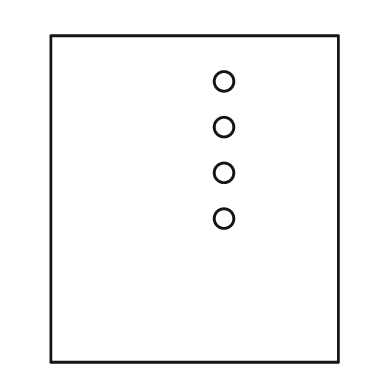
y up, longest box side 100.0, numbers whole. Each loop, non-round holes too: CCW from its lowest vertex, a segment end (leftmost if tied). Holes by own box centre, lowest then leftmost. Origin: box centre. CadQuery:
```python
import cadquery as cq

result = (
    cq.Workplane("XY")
    .moveTo(-44.0, -50.0)
    .lineTo(44.0, -50.0)
    .lineTo(44.0, 50.0)
    .lineTo(-44.0, 50.0)
    .close()
    .moveTo(9.0, -6.0)
    .circle(3.0)
    .moveTo(9.0, 8.0)
    .circle(3.0)
    .moveTo(9.0, 22.0)
    .circle(3.0)
    .moveTo(9.0, 36.0)
    .circle(3.0)
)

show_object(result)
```